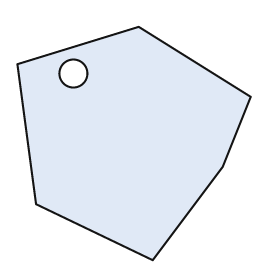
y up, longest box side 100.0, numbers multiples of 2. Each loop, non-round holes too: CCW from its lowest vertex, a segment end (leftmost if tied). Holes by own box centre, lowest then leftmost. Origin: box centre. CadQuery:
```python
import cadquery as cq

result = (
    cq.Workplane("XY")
    .moveTo(8.0, -50.0)
    .lineTo(38.0, -10.0)
    .lineTo(50.0, 20.0)
    .lineTo(2.0, 50.0)
    .lineTo(-50.0, 34.0)
    .lineTo(-42.0, -26.0)
    .close()
    .moveTo(-26.0, 30.0)
    .circle(6.0)
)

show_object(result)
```